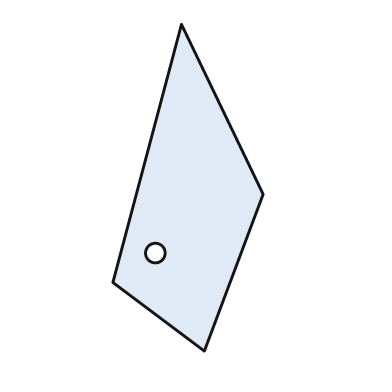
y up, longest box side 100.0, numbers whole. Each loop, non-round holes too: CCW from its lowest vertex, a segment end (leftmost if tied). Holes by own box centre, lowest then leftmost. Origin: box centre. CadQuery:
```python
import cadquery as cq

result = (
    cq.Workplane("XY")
    .moveTo(5.0, -50.0)
    .lineTo(23.0, -2.0)
    .lineTo(-2.0, 50.0)
    .lineTo(-23.0, -29.0)
    .close()
    .moveTo(-10.0, -20.0)
    .circle(3.0)
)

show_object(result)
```